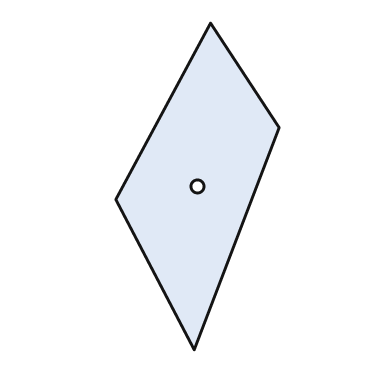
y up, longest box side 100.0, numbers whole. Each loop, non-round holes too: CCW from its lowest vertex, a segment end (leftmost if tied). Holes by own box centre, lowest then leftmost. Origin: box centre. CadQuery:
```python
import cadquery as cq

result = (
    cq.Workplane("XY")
    .moveTo(-1.0, -50.0)
    .lineTo(25.0, 18.0)
    .lineTo(4.0, 50.0)
    .lineTo(-25.0, -4.0)
    .close()
    .moveTo(0.0, 0.0)
    .circle(2.0)
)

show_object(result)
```